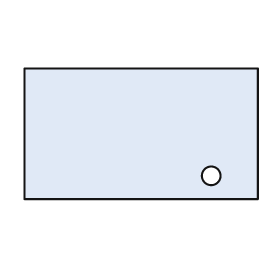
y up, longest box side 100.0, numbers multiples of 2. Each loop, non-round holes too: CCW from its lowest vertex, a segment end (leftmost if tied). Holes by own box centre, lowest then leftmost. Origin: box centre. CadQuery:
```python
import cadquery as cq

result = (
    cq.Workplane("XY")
    .moveTo(-50.0, -28.0)
    .lineTo(50.0, -28.0)
    .lineTo(50.0, 28.0)
    .lineTo(-50.0, 28.0)
    .close()
    .moveTo(30.0, -18.0)
    .circle(4.0)
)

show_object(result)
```